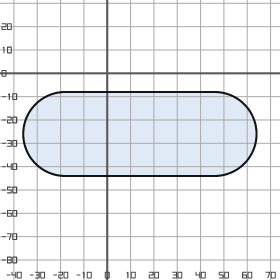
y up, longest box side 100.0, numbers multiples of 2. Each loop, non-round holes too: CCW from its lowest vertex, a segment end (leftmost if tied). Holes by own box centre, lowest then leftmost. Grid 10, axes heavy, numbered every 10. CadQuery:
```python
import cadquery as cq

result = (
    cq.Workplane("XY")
    .moveTo(-18.0, -44.0)
    .lineTo(46.0, -44.0)
    .threePointArc((64.0, -26.0), (46.0, -8.0))
    .lineTo(-18.0, -8.0)
    .threePointArc((-36.0, -26.0), (-18.0, -44.0))
    .close()
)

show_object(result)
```